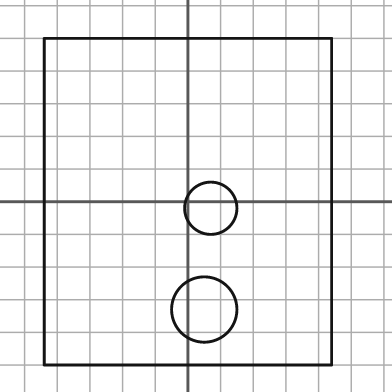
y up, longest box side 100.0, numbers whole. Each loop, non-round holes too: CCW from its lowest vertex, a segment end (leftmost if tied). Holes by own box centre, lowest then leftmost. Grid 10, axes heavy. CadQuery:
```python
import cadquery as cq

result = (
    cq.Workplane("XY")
    .moveTo(-44.0, -50.0)
    .lineTo(44.0, -50.0)
    .lineTo(44.0, 50.0)
    .lineTo(-44.0, 50.0)
    .close()
    .moveTo(5.0, -33.0)
    .circle(10.0)
    .moveTo(7.0, -2.0)
    .circle(8.0)
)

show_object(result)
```